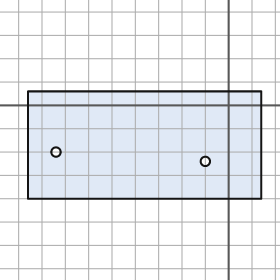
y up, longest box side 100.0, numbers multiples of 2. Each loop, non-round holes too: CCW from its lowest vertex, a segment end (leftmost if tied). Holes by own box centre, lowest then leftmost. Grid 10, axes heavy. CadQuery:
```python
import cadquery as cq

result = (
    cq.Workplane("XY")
    .moveTo(-86.0, -40.0)
    .lineTo(14.0, -40.0)
    .lineTo(14.0, 6.0)
    .lineTo(-86.0, 6.0)
    .close()
    .moveTo(-10.0, -24.0)
    .circle(2.0)
    .moveTo(-74.0, -20.0)
    .circle(2.0)
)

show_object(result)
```